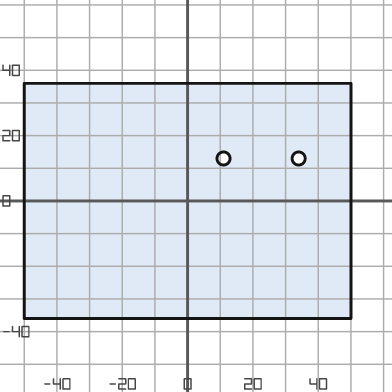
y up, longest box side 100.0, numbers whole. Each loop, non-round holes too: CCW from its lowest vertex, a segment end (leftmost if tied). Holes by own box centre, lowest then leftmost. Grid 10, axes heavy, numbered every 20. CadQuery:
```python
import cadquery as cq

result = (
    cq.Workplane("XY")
    .moveTo(-50.0, -36.0)
    .lineTo(50.0, -36.0)
    .lineTo(50.0, 36.0)
    .lineTo(-50.0, 36.0)
    .close()
    .moveTo(11.0, 13.0)
    .circle(2.0)
    .moveTo(34.0, 13.0)
    .circle(2.0)
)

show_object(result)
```